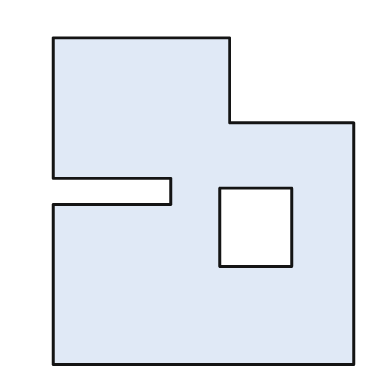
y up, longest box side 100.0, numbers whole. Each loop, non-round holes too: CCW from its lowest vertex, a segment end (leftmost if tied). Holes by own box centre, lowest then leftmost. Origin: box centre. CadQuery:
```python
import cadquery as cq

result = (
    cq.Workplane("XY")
    .moveTo(-46.0, -50.0)
    .lineTo(46.0, -50.0)
    .lineTo(46.0, 24.0)
    .lineTo(8.0, 24.0)
    .lineTo(8.0, 50.0)
    .lineTo(-46.0, 50.0)
    .lineTo(-46.0, 7.0)
    .lineTo(-10.0, 7.0)
    .lineTo(-10.0, -1.0)
    .lineTo(-46.0, -1.0)
    .close()
    .moveTo(5.0, -20.0)
    .lineTo(27.0, -20.0)
    .lineTo(27.0, 4.0)
    .lineTo(5.0, 4.0)
    .close()
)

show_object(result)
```